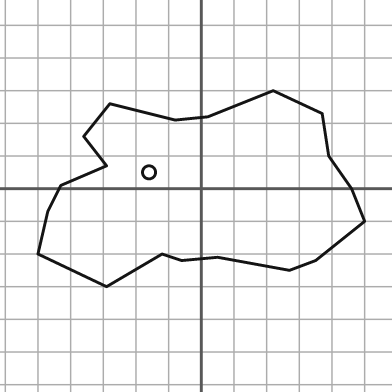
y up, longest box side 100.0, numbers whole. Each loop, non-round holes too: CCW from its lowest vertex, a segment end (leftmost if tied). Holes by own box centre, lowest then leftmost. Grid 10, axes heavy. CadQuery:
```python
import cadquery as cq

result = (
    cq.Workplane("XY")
    .moveTo(-29.0, -30.0)
    .lineTo(-12.0, -20.0)
    .lineTo(-6.0, -22.0)
    .lineTo(5.0, -21.0)
    .lineTo(27.0, -25.0)
    .lineTo(35.0, -22.0)
    .lineTo(50.0, -10.0)
    .lineTo(46.0, 0.0)
    .lineTo(39.0, 10.0)
    .lineTo(37.0, 23.0)
    .lineTo(22.0, 30.0)
    .lineTo(2.0, 22.0)
    .lineTo(-8.0, 21.0)
    .lineTo(-28.0, 26.0)
    .lineTo(-36.0, 16.0)
    .lineTo(-29.0, 7.0)
    .lineTo(-43.0, 1.0)
    .lineTo(-47.0, -7.0)
    .lineTo(-50.0, -20.0)
    .close()
    .moveTo(-16.0, 5.0)
    .circle(2.0)
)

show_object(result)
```